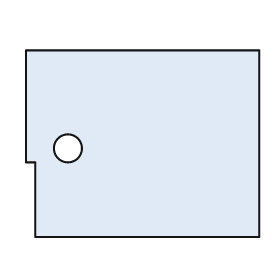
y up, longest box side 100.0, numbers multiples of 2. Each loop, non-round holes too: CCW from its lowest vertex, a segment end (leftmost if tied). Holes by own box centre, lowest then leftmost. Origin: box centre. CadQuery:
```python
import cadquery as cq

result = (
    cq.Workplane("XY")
    .moveTo(-46.0, -40.0)
    .lineTo(50.0, -40.0)
    .lineTo(50.0, 40.0)
    .lineTo(-50.0, 40.0)
    .lineTo(-50.0, -8.0)
    .lineTo(-46.0, -8.0)
    .close()
    .moveTo(-32.0, -2.0)
    .circle(6.0)
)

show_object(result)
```